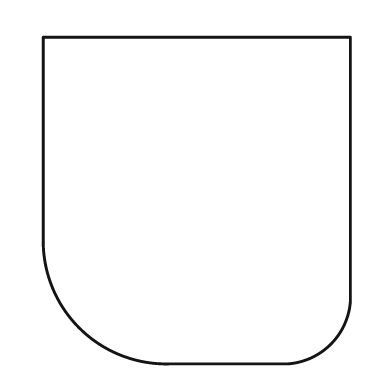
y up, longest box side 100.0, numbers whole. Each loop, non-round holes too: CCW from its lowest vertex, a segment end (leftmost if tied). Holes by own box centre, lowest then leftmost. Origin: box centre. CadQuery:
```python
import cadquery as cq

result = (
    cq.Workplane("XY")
    .moveTo(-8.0, -50.0)
    .lineTo(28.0, -50.0)
    .threePointArc((41.0, -44.0), (47.0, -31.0))
    .lineTo(47.0, 50.0)
    .lineTo(-47.0, 50.0)
    .lineTo(-47.0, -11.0)
    .threePointArc((-36.0, -39.0), (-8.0, -50.0))
    .close()
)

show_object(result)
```